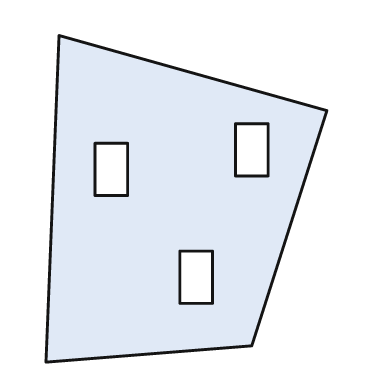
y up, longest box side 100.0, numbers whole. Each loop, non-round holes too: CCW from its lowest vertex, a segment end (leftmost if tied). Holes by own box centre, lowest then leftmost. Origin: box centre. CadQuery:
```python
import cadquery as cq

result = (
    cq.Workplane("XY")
    .moveTo(-43.0, -50.0)
    .lineTo(20.0, -45.0)
    .lineTo(43.0, 27.0)
    .lineTo(-39.0, 50.0)
    .close()
    .moveTo(-2.0, -32.0)
    .lineTo(8.0, -32.0)
    .lineTo(8.0, -16.0)
    .lineTo(-2.0, -16.0)
    .close()
    .moveTo(-28.0, 1.0)
    .lineTo(-18.0, 1.0)
    .lineTo(-18.0, 17.0)
    .lineTo(-28.0, 17.0)
    .close()
    .moveTo(15.0, 7.0)
    .lineTo(25.0, 7.0)
    .lineTo(25.0, 23.0)
    .lineTo(15.0, 23.0)
    .close()
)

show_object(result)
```